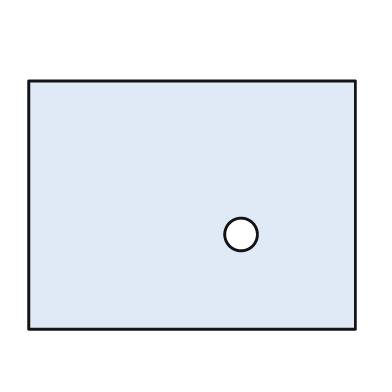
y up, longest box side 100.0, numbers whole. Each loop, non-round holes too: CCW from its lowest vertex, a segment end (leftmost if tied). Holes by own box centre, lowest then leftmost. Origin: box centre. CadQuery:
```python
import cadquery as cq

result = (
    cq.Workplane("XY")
    .moveTo(-50.0, -38.0)
    .lineTo(50.0, -38.0)
    .lineTo(50.0, 38.0)
    .lineTo(-50.0, 38.0)
    .close()
    .moveTo(15.0, -9.0)
    .circle(5.0)
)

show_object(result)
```